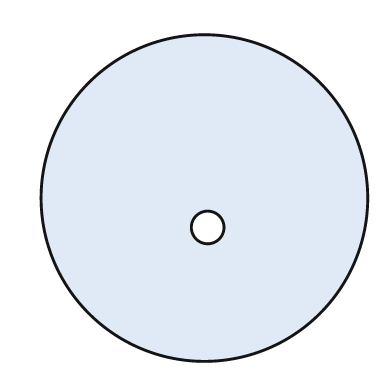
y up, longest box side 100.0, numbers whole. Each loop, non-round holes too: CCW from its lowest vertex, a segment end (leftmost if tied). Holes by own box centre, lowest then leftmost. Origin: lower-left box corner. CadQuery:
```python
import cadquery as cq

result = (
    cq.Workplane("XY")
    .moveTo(50.0, 50.0)
    .circle(50.0)
    .moveTo(51.0, 41.0)
    .circle(5.0)
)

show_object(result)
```